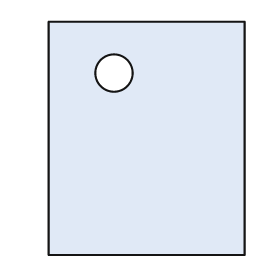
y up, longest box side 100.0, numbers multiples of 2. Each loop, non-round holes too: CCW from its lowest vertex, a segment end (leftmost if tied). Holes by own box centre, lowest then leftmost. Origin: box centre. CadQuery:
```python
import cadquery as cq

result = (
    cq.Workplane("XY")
    .moveTo(-42.0, -50.0)
    .lineTo(42.0, -50.0)
    .lineTo(42.0, 50.0)
    .lineTo(-42.0, 50.0)
    .close()
    .moveTo(-14.0, 28.0)
    .circle(8.0)
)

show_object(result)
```